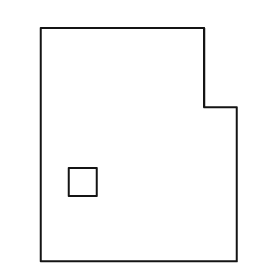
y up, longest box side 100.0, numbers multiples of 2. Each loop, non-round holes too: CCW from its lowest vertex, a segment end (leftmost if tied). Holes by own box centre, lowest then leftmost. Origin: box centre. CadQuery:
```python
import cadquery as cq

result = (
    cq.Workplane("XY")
    .moveTo(-42.0, -50.0)
    .lineTo(42.0, -50.0)
    .lineTo(42.0, 16.0)
    .lineTo(28.0, 16.0)
    .lineTo(28.0, 50.0)
    .lineTo(-42.0, 50.0)
    .close()
    .moveTo(-30.0, -22.0)
    .lineTo(-18.0, -22.0)
    .lineTo(-18.0, -10.0)
    .lineTo(-30.0, -10.0)
    .close()
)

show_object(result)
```